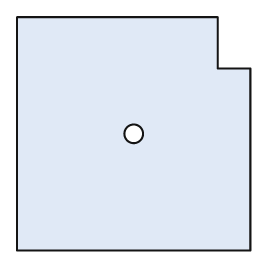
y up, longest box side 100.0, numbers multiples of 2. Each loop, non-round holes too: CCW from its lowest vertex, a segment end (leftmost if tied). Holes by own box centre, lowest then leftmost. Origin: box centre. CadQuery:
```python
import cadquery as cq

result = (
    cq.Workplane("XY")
    .moveTo(-50.0, -50.0)
    .lineTo(50.0, -50.0)
    .lineTo(50.0, 28.0)
    .lineTo(36.0, 28.0)
    .lineTo(36.0, 50.0)
    .lineTo(-50.0, 50.0)
    .close()
    .moveTo(0.0, 0.0)
    .circle(4.0)
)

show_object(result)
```